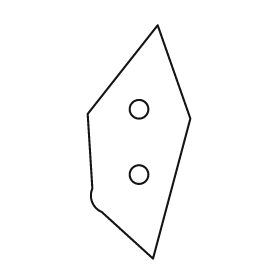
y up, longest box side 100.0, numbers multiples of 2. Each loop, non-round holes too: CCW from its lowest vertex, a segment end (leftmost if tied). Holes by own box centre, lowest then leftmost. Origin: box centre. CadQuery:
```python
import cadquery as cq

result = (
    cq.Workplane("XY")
    .moveTo(6.0, -50.0)
    .lineTo(22.0, 10.0)
    .lineTo(8.0, 50.0)
    .lineTo(-22.0, 12.0)
    .lineTo(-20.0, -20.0)
    .threePointArc((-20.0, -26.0), (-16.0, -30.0))
    .close()
    .moveTo(0.0, -14.0)
    .circle(4.0)
    .moveTo(0.0, 14.0)
    .circle(4.0)
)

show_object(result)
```